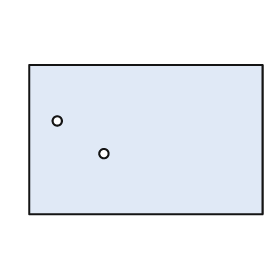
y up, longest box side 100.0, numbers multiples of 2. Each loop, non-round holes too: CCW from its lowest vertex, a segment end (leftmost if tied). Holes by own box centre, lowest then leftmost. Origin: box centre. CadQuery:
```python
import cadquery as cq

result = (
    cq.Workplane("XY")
    .moveTo(-50.0, -32.0)
    .lineTo(50.0, -32.0)
    .lineTo(50.0, 32.0)
    .lineTo(-50.0, 32.0)
    .close()
    .moveTo(-18.0, -6.0)
    .circle(2.0)
    .moveTo(-38.0, 8.0)
    .circle(2.0)
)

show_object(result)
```